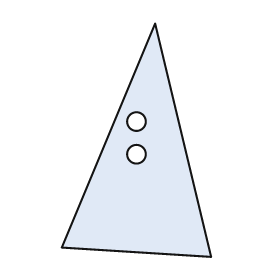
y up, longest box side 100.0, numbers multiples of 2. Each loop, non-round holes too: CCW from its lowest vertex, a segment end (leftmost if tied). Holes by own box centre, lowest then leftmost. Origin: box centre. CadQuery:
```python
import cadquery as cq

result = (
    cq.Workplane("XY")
    .moveTo(32.0, -50.0)
    .lineTo(8.0, 50.0)
    .lineTo(-32.0, -46.0)
    .close()
    .moveTo(0.0, -6.0)
    .circle(4.0)
    .moveTo(0.0, 8.0)
    .circle(4.0)
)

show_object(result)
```